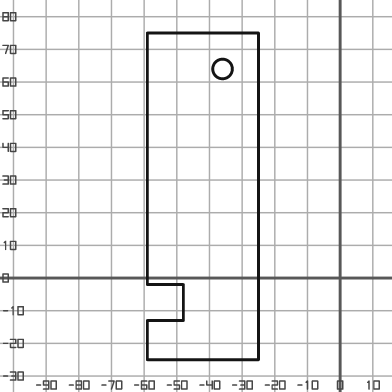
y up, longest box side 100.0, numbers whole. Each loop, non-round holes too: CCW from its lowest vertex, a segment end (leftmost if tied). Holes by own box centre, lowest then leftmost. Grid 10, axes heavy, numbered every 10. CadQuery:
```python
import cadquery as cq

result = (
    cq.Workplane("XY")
    .moveTo(-59.0, -25.0)
    .lineTo(-25.0, -25.0)
    .lineTo(-25.0, 75.0)
    .lineTo(-59.0, 75.0)
    .lineTo(-59.0, -2.0)
    .lineTo(-48.0, -2.0)
    .lineTo(-48.0, -13.0)
    .lineTo(-59.0, -13.0)
    .close()
    .moveTo(-36.0, 64.0)
    .circle(3.0)
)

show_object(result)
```